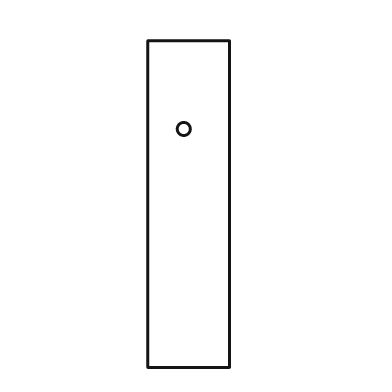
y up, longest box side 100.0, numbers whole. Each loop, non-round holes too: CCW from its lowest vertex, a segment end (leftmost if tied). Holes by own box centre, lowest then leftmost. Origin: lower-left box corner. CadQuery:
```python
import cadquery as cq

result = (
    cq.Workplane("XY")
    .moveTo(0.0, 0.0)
    .lineTo(25.0, 0.0)
    .lineTo(25.0, 100.0)
    .lineTo(0.0, 100.0)
    .close()
    .moveTo(11.0, 73.0)
    .circle(2.0)
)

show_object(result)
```